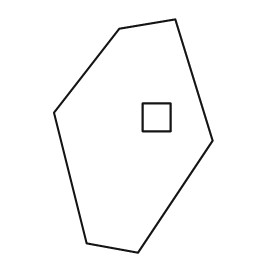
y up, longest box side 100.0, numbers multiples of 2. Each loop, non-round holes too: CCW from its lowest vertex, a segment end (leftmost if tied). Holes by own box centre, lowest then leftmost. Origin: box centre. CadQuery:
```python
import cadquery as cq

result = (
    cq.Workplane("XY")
    .moveTo(2.0, -50.0)
    .lineTo(34.0, -2.0)
    .lineTo(18.0, 50.0)
    .lineTo(-6.0, 46.0)
    .lineTo(-34.0, 10.0)
    .lineTo(-20.0, -46.0)
    .close()
    .moveTo(4.0, 2.0)
    .lineTo(16.0, 2.0)
    .lineTo(16.0, 14.0)
    .lineTo(4.0, 14.0)
    .close()
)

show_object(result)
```